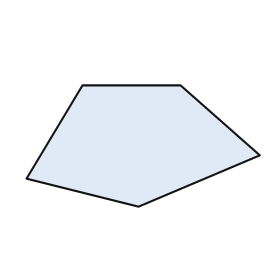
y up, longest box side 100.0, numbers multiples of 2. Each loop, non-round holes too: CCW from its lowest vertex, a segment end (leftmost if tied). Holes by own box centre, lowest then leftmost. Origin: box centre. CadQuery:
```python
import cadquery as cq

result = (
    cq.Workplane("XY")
    .moveTo(-2.0, -26.0)
    .lineTo(50.0, -4.0)
    .lineTo(16.0, 26.0)
    .lineTo(-26.0, 26.0)
    .lineTo(-50.0, -14.0)
    .close()
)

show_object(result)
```